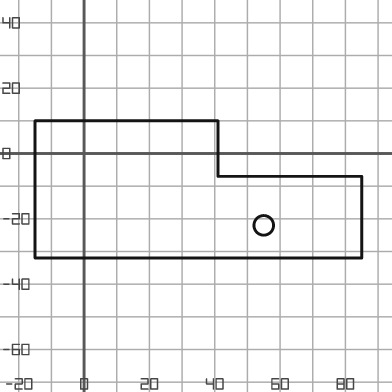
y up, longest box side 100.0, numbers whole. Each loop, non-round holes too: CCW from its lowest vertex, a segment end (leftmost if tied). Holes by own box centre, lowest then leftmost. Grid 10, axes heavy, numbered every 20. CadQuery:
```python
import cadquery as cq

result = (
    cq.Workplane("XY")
    .moveTo(-15.0, -32.0)
    .lineTo(85.0, -32.0)
    .lineTo(85.0, -7.0)
    .lineTo(41.0, -7.0)
    .lineTo(41.0, 10.0)
    .lineTo(-15.0, 10.0)
    .close()
    .moveTo(55.0, -22.0)
    .circle(3.0)
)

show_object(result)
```